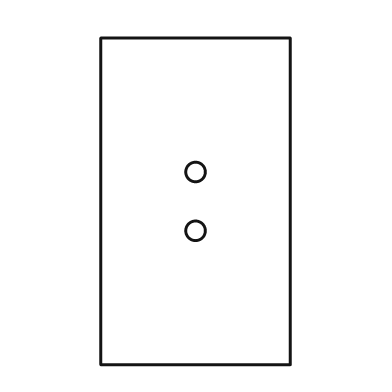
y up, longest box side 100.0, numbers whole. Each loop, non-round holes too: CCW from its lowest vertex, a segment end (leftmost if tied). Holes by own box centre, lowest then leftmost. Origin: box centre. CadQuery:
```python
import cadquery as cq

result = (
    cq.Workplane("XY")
    .moveTo(-29.0, -50.0)
    .lineTo(29.0, -50.0)
    .lineTo(29.0, 50.0)
    .lineTo(-29.0, 50.0)
    .close()
    .moveTo(0.0, -9.0)
    .circle(3.0)
    .moveTo(0.0, 9.0)
    .circle(3.0)
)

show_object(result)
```